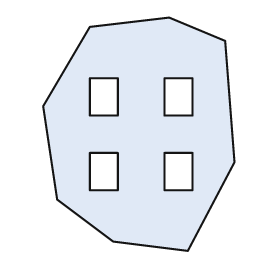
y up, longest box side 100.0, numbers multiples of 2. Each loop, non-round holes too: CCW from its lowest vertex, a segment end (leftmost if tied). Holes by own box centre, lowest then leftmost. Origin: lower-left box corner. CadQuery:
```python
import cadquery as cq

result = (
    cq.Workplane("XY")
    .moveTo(62.0, 0.0)
    .lineTo(82.0, 38.0)
    .lineTo(78.0, 90.0)
    .lineTo(54.0, 100.0)
    .lineTo(20.0, 96.0)
    .lineTo(0.0, 62.0)
    .lineTo(6.0, 22.0)
    .lineTo(30.0, 4.0)
    .close()
    .moveTo(20.0, 26.0)
    .lineTo(32.0, 26.0)
    .lineTo(32.0, 42.0)
    .lineTo(20.0, 42.0)
    .close()
    .moveTo(52.0, 26.0)
    .lineTo(64.0, 26.0)
    .lineTo(64.0, 42.0)
    .lineTo(52.0, 42.0)
    .close()
    .moveTo(20.0, 58.0)
    .lineTo(32.0, 58.0)
    .lineTo(32.0, 74.0)
    .lineTo(20.0, 74.0)
    .close()
    .moveTo(52.0, 58.0)
    .lineTo(64.0, 58.0)
    .lineTo(64.0, 74.0)
    .lineTo(52.0, 74.0)
    .close()
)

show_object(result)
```